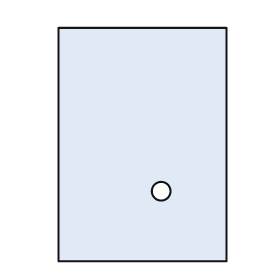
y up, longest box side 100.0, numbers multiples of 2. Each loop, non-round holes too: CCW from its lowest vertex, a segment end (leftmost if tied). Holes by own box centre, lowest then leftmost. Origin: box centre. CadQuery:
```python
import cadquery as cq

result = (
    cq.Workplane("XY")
    .moveTo(-36.0, -50.0)
    .lineTo(36.0, -50.0)
    .lineTo(36.0, 50.0)
    .lineTo(-36.0, 50.0)
    .close()
    .moveTo(8.0, -20.0)
    .circle(4.0)
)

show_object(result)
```